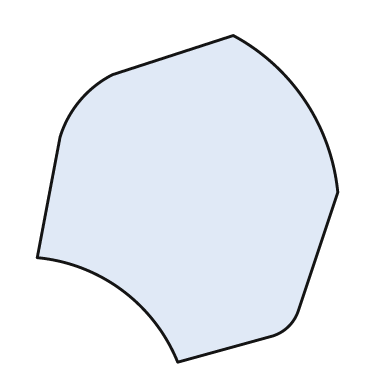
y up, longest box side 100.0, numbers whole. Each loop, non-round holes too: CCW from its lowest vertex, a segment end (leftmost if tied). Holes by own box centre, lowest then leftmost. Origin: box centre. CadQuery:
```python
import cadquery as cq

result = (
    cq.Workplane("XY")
    .moveTo(-3.0, -50.0)
    .lineTo(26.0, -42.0)
    .threePointArc((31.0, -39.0), (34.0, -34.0))
    .lineTo(46.0, 2.0)
    .threePointArc((36.0, 30.0), (14.0, 50.0))
    .lineTo(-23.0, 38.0)
    .threePointArc((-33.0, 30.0), (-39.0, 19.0))
    .lineTo(-46.0, -18.0)
    .threePointArc((-20.0, -28.0), (-3.0, -50.0))
    .close()
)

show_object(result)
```